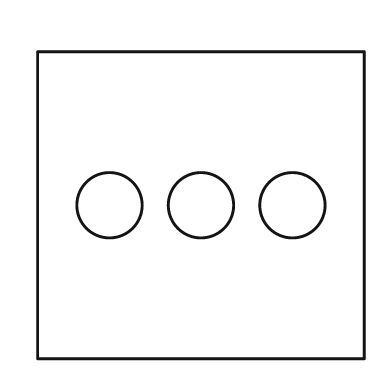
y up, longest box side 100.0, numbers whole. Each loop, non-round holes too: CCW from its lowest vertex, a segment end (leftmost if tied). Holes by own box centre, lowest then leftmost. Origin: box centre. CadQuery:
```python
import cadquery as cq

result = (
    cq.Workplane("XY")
    .moveTo(-50.0, -47.0)
    .lineTo(50.0, -47.0)
    .lineTo(50.0, 47.0)
    .lineTo(-50.0, 47.0)
    .close()
    .moveTo(-28.0, 0.0)
    .circle(10.0)
    .moveTo(0.0, 0.0)
    .circle(10.0)
    .moveTo(28.0, 0.0)
    .circle(10.0)
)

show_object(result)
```